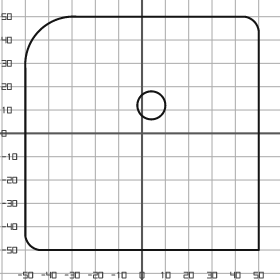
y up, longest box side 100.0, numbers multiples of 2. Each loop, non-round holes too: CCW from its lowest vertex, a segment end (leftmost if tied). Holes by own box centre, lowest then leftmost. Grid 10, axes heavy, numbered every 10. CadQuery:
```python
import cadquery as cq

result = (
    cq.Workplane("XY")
    .moveTo(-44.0, -50.0)
    .lineTo(50.0, -50.0)
    .lineTo(50.0, 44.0)
    .threePointArc((48.0, 48.0), (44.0, 50.0))
    .lineTo(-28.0, 50.0)
    .threePointArc((-44.0, 44.0), (-50.0, 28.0))
    .lineTo(-50.0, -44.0)
    .threePointArc((-48.0, -48.0), (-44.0, -50.0))
    .close()
    .moveTo(4.0, 12.0)
    .circle(6.0)
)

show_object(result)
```